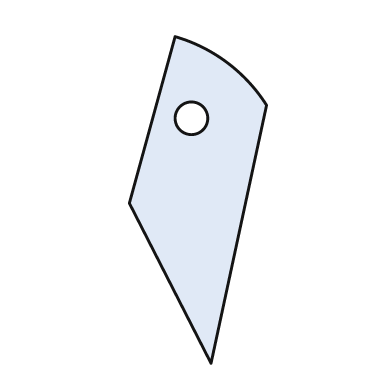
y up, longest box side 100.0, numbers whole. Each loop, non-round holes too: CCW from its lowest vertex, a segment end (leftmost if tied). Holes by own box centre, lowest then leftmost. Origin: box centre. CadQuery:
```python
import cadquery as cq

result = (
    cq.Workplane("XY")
    .moveTo(4.0, -50.0)
    .lineTo(21.0, 29.0)
    .threePointArc((9.0, 42.0), (-7.0, 50.0))
    .lineTo(-21.0, -1.0)
    .close()
    .moveTo(-2.0, 25.0)
    .circle(5.0)
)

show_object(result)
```